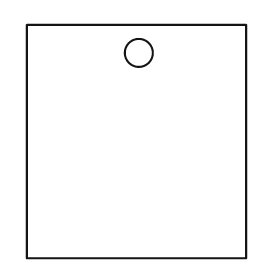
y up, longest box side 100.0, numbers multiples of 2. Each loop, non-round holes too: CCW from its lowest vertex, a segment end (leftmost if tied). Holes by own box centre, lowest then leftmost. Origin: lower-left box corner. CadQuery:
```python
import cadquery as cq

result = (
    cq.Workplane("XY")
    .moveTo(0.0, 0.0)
    .lineTo(94.0, 0.0)
    .lineTo(94.0, 100.0)
    .lineTo(0.0, 100.0)
    .close()
    .moveTo(48.0, 88.0)
    .circle(6.0)
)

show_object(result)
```